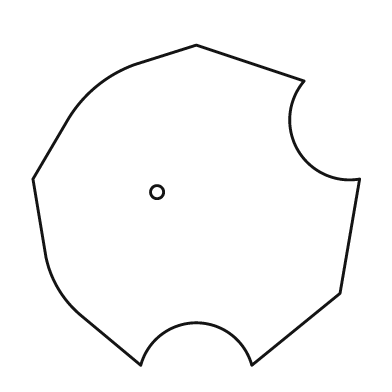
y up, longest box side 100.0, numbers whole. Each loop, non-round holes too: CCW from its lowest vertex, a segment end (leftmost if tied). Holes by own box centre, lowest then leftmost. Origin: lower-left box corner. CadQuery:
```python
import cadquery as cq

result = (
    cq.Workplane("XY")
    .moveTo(33.0, 0.0)
    .threePointArc((50.0, 13.0), (67.0, 0.0))
    .lineTo(94.0, 22.0)
    .lineTo(100.0, 57.0)
    .threePointArc((81.0, 66.0), (83.0, 87.0))
    .lineTo(50.0, 98.0)
    .lineTo(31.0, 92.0)
    .threePointArc((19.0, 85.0), (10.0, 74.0))
    .lineTo(0.0, 57.0)
    .lineTo(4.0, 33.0)
    .threePointArc((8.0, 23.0), (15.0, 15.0))
    .close()
    .moveTo(38.0, 53.0)
    .circle(2.0)
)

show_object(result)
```